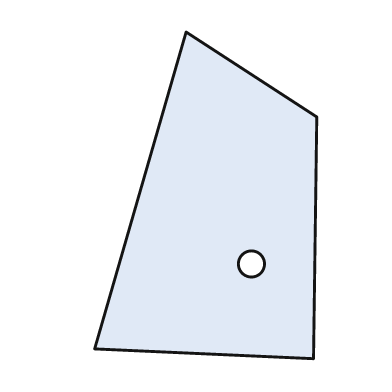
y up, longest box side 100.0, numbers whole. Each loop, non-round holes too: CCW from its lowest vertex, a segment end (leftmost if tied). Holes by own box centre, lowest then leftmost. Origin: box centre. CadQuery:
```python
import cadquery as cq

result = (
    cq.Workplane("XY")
    .moveTo(33.0, -50.0)
    .lineTo(34.0, 24.0)
    .lineTo(-6.0, 50.0)
    .lineTo(-34.0, -47.0)
    .close()
    .moveTo(14.0, -21.0)
    .circle(4.0)
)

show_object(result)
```